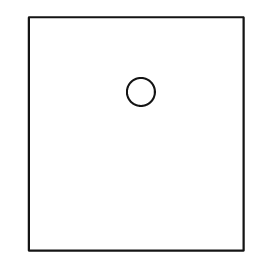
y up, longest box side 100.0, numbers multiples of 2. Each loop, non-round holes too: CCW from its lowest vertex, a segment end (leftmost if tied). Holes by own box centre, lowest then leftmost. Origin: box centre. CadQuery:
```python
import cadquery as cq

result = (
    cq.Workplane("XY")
    .moveTo(-46.0, -50.0)
    .lineTo(46.0, -50.0)
    .lineTo(46.0, 50.0)
    .lineTo(-46.0, 50.0)
    .close()
    .moveTo(2.0, 18.0)
    .circle(6.0)
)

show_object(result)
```